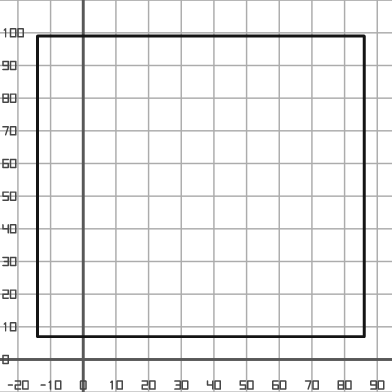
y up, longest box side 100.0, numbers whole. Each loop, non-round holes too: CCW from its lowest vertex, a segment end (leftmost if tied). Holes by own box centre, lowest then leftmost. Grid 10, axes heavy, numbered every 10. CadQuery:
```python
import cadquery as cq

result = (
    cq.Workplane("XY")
    .moveTo(-14.0, 7.0)
    .lineTo(86.0, 7.0)
    .lineTo(86.0, 99.0)
    .lineTo(-14.0, 99.0)
    .close()
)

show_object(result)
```